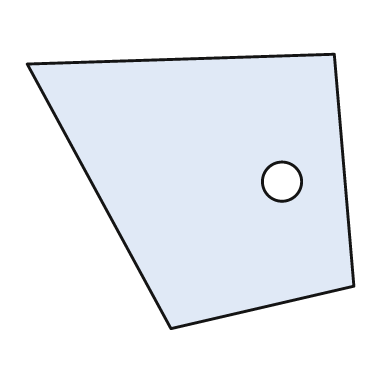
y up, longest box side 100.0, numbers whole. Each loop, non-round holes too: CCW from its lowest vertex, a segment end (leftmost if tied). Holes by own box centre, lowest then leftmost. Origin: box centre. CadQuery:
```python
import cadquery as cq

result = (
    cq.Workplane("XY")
    .moveTo(-6.0, -42.0)
    .lineTo(50.0, -29.0)
    .lineTo(44.0, 42.0)
    .lineTo(-50.0, 39.0)
    .close()
    .moveTo(28.0, 3.0)
    .circle(6.0)
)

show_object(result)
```